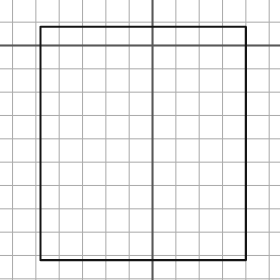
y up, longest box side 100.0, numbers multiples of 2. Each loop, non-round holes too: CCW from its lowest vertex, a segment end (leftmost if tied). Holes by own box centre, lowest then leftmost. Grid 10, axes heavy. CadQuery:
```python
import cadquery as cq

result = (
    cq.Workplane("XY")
    .moveTo(-48.0, -92.0)
    .lineTo(40.0, -92.0)
    .lineTo(40.0, 8.0)
    .lineTo(-48.0, 8.0)
    .close()
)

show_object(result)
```